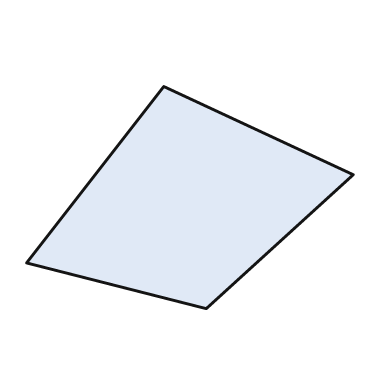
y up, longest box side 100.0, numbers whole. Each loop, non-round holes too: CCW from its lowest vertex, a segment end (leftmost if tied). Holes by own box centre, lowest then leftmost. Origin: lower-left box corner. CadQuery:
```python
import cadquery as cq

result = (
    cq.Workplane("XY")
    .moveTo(55.0, 0.0)
    .lineTo(100.0, 41.0)
    .lineTo(42.0, 68.0)
    .lineTo(0.0, 14.0)
    .close()
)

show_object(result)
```